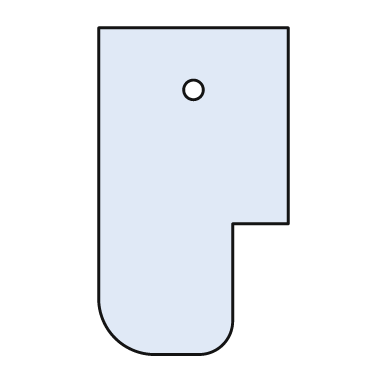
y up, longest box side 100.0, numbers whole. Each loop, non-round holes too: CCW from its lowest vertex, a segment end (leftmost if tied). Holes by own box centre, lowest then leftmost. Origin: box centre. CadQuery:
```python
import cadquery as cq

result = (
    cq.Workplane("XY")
    .moveTo(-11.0, -50.0)
    .lineTo(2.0, -50.0)
    .threePointArc((9.0, -47.0), (12.0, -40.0))
    .lineTo(12.0, -10.0)
    .lineTo(29.0, -10.0)
    .lineTo(29.0, 50.0)
    .lineTo(-29.0, 50.0)
    .lineTo(-29.0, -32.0)
    .threePointArc((-24.0, -45.0), (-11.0, -50.0))
    .close()
    .moveTo(0.0, 31.0)
    .circle(3.0)
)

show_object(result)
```